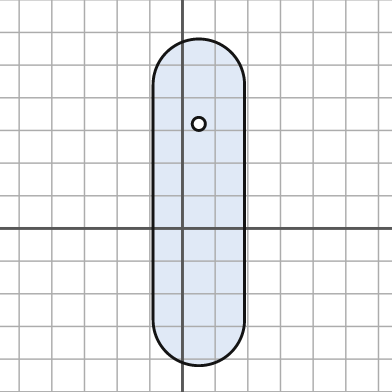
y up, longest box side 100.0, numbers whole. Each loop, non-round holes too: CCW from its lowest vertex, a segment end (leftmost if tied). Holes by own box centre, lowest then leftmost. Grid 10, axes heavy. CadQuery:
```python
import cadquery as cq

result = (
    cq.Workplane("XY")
    .moveTo(-9.0, -28.0)
    .threePointArc((5.0, -42.0), (19.0, -28.0))
    .lineTo(19.0, 44.0)
    .threePointArc((5.0, 58.0), (-9.0, 44.0))
    .close()
    .moveTo(5.0, 32.0)
    .circle(2.0)
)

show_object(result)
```